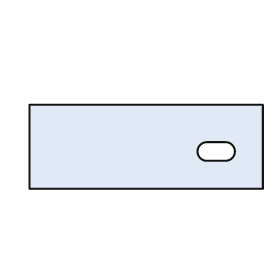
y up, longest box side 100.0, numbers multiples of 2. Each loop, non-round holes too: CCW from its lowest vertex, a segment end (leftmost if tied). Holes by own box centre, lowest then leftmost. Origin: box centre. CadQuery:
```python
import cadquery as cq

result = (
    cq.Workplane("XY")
    .moveTo(-50.0, -18.0)
    .lineTo(50.0, -18.0)
    .lineTo(50.0, 18.0)
    .lineTo(-50.0, 18.0)
    .close()
    .moveTo(26.0, -6.0)
    .lineTo(34.0, -6.0)
    .threePointArc((38.0, -2.0), (34.0, 2.0))
    .lineTo(26.0, 2.0)
    .threePointArc((22.0, -2.0), (26.0, -6.0))
    .close()
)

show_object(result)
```